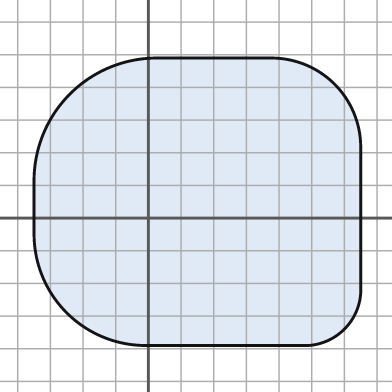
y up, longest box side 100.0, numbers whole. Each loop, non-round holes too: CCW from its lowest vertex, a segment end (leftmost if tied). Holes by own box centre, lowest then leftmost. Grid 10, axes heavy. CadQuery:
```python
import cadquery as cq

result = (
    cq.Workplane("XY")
    .moveTo(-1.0, -39.0)
    .lineTo(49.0, -39.0)
    .threePointArc((60.0, -34.0), (65.0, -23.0))
    .lineTo(65.0, 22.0)
    .threePointArc((57.0, 41.0), (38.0, 49.0))
    .lineTo(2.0, 49.0)
    .threePointArc((-24.0, 38.0), (-35.0, 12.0))
    .lineTo(-35.0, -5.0)
    .threePointArc((-25.0, -29.0), (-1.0, -39.0))
    .close()
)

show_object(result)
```